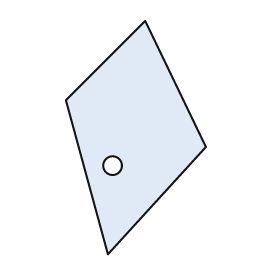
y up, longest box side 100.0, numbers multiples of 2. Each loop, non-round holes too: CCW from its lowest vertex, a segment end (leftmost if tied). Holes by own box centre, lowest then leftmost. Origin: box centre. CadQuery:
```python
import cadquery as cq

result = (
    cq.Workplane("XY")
    .moveTo(-12.0, -50.0)
    .lineTo(30.0, -4.0)
    .lineTo(4.0, 50.0)
    .lineTo(-30.0, 16.0)
    .close()
    .moveTo(-10.0, -12.0)
    .circle(4.0)
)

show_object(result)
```